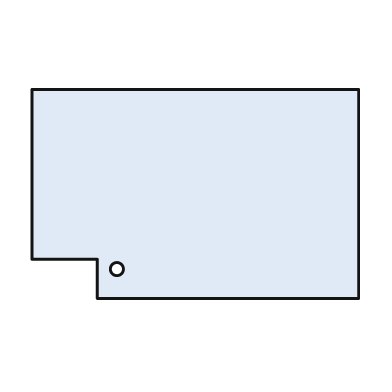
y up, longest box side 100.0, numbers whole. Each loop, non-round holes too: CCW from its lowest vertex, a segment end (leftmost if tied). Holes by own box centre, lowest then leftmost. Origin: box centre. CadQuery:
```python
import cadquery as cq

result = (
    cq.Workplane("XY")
    .moveTo(-30.0, -32.0)
    .lineTo(50.0, -32.0)
    .lineTo(50.0, 32.0)
    .lineTo(-50.0, 32.0)
    .lineTo(-50.0, -20.0)
    .lineTo(-30.0, -20.0)
    .close()
    .moveTo(-24.0, -23.0)
    .circle(2.0)
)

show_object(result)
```